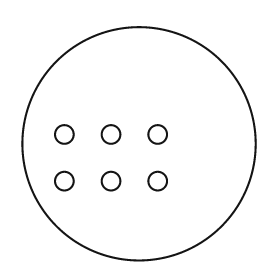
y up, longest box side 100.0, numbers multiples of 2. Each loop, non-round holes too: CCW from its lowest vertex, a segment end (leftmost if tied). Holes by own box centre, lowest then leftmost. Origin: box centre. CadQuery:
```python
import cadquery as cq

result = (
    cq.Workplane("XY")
    .moveTo(0.0, 0.0)
    .circle(50.0)
    .moveTo(-32.0, -16.0)
    .circle(4.0)
    .moveTo(-12.0, -16.0)
    .circle(4.0)
    .moveTo(8.0, -16.0)
    .circle(4.0)
    .moveTo(-32.0, 4.0)
    .circle(4.0)
    .moveTo(-12.0, 4.0)
    .circle(4.0)
    .moveTo(8.0, 4.0)
    .circle(4.0)
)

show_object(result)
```